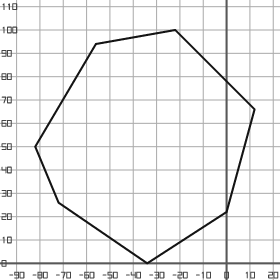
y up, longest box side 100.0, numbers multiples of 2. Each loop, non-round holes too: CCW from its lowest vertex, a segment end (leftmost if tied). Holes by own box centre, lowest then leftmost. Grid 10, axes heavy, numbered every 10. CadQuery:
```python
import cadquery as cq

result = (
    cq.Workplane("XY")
    .moveTo(-34.0, 0.0)
    .lineTo(0.0, 22.0)
    .lineTo(12.0, 66.0)
    .lineTo(-22.0, 100.0)
    .lineTo(-56.0, 94.0)
    .lineTo(-82.0, 50.0)
    .lineTo(-72.0, 26.0)
    .close()
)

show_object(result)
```